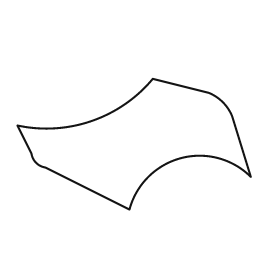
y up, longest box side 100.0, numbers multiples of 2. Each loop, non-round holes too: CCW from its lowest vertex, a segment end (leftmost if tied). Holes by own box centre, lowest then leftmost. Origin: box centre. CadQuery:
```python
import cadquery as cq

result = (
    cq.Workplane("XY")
    .moveTo(-2.0, -28.0)
    .threePointArc((20.0, -6.0), (50.0, -14.0))
    .lineTo(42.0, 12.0)
    .threePointArc((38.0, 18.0), (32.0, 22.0))
    .lineTo(8.0, 28.0)
    .threePointArc((-18.0, 10.0), (-50.0, 8.0))
    .lineTo(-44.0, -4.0)
    .threePointArc((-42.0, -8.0), (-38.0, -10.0))
    .close()
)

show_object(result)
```